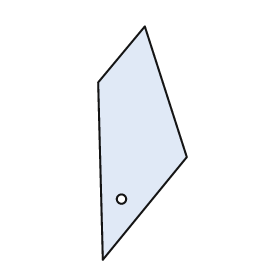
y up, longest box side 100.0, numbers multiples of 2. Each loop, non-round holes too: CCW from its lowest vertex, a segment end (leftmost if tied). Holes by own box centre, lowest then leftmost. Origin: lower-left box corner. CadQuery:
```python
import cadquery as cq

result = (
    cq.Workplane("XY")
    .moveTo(2.0, 0.0)
    .lineTo(38.0, 44.0)
    .lineTo(20.0, 100.0)
    .lineTo(0.0, 76.0)
    .close()
    .moveTo(10.0, 26.0)
    .circle(2.0)
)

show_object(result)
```